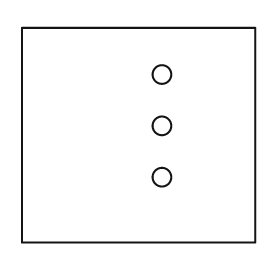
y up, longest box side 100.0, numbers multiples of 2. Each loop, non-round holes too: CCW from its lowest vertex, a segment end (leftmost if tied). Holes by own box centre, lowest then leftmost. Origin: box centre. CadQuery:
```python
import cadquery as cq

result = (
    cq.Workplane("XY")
    .moveTo(-50.0, -46.0)
    .lineTo(50.0, -46.0)
    .lineTo(50.0, 46.0)
    .lineTo(-50.0, 46.0)
    .close()
    .moveTo(10.0, -18.0)
    .circle(4.0)
    .moveTo(10.0, 4.0)
    .circle(4.0)
    .moveTo(10.0, 26.0)
    .circle(4.0)
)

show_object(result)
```